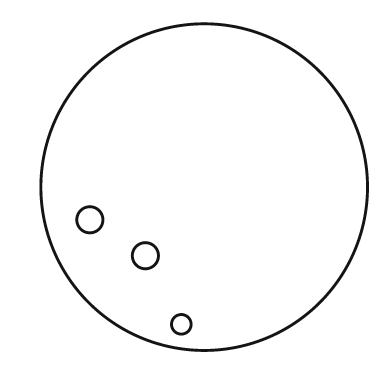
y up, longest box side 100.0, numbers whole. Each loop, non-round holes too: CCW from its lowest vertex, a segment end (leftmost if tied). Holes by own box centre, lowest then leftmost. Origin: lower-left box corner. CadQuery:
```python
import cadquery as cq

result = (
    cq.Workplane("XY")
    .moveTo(50.0, 50.0)
    .circle(50.0)
    .moveTo(43.0, 8.0)
    .circle(3.0)
    .moveTo(32.0, 29.0)
    .circle(4.0)
    .moveTo(15.0, 40.0)
    .circle(4.0)
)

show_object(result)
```